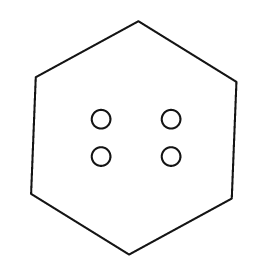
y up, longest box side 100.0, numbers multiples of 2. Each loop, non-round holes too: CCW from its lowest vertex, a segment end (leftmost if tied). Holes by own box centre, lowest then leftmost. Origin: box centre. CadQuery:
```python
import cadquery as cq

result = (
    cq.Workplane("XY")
    .moveTo(-2.0, -50.0)
    .lineTo(42.0, -26.0)
    .lineTo(44.0, 24.0)
    .lineTo(2.0, 50.0)
    .lineTo(-42.0, 26.0)
    .lineTo(-44.0, -24.0)
    .close()
    .moveTo(-14.0, -8.0)
    .circle(4.0)
    .moveTo(16.0, -8.0)
    .circle(4.0)
    .moveTo(-14.0, 8.0)
    .circle(4.0)
    .moveTo(16.0, 8.0)
    .circle(4.0)
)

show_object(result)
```